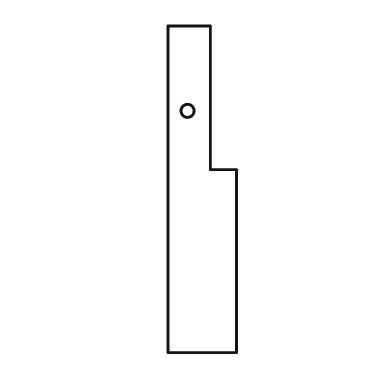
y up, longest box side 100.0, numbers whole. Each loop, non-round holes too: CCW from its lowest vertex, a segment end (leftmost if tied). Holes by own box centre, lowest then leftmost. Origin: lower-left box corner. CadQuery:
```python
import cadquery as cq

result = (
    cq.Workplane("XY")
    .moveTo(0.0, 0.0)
    .lineTo(21.0, 0.0)
    .lineTo(21.0, 56.0)
    .lineTo(13.0, 56.0)
    .lineTo(13.0, 100.0)
    .lineTo(0.0, 100.0)
    .close()
    .moveTo(6.0, 74.0)
    .circle(2.0)
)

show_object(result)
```